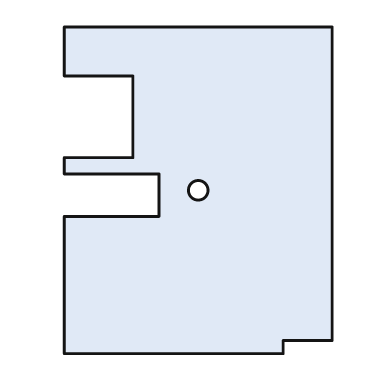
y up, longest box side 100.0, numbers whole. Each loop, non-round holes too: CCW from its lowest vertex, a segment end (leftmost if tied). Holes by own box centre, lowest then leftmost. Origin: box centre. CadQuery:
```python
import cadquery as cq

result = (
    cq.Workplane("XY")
    .moveTo(-41.0, -50.0)
    .lineTo(26.0, -50.0)
    .lineTo(26.0, -46.0)
    .lineTo(41.0, -46.0)
    .lineTo(41.0, 50.0)
    .lineTo(-41.0, 50.0)
    .lineTo(-41.0, 35.0)
    .lineTo(-20.0, 35.0)
    .lineTo(-20.0, 10.0)
    .lineTo(-41.0, 10.0)
    .lineTo(-41.0, 5.0)
    .lineTo(-12.0, 5.0)
    .lineTo(-12.0, -8.0)
    .lineTo(-41.0, -8.0)
    .close()
    .moveTo(0.0, 0.0)
    .circle(3.0)
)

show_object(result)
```